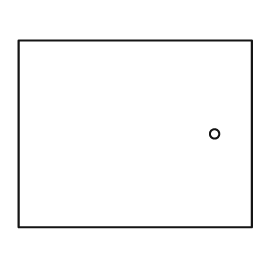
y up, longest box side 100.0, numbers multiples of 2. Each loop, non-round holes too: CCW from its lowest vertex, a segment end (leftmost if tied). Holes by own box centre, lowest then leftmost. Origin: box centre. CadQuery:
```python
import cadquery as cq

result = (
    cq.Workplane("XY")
    .moveTo(-50.0, -40.0)
    .lineTo(50.0, -40.0)
    .lineTo(50.0, 40.0)
    .lineTo(-50.0, 40.0)
    .close()
    .moveTo(34.0, 0.0)
    .circle(2.0)
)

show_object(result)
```